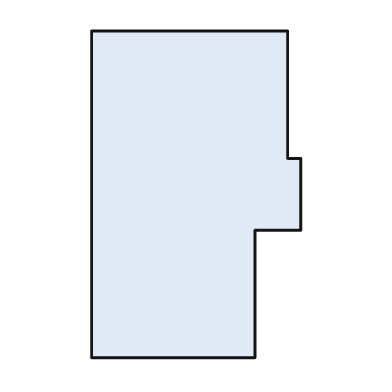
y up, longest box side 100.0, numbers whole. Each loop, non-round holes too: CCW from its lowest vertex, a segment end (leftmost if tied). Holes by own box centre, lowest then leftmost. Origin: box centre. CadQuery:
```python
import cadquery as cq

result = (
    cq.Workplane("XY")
    .moveTo(-32.0, -50.0)
    .lineTo(18.0, -50.0)
    .lineTo(18.0, -11.0)
    .lineTo(32.0, -11.0)
    .lineTo(32.0, 11.0)
    .lineTo(28.0, 11.0)
    .lineTo(28.0, 50.0)
    .lineTo(-32.0, 50.0)
    .close()
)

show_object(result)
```